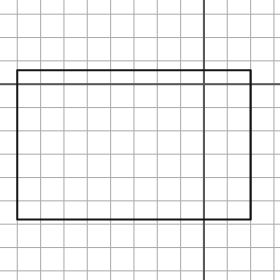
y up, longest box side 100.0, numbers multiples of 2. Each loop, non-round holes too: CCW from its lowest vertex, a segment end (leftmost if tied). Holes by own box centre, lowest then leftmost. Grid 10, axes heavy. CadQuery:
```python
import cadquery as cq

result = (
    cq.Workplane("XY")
    .moveTo(-80.0, -58.0)
    .lineTo(20.0, -58.0)
    .lineTo(20.0, 6.0)
    .lineTo(-80.0, 6.0)
    .close()
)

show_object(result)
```